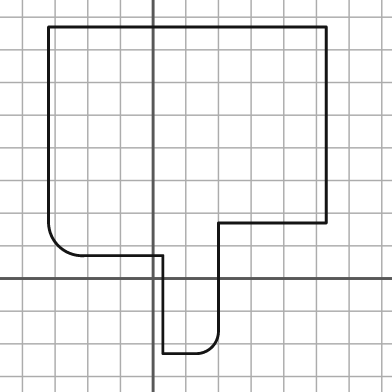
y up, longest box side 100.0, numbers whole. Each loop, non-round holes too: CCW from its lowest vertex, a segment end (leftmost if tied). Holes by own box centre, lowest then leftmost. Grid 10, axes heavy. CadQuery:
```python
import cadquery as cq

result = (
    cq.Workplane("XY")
    .moveTo(3.0, -23.0)
    .lineTo(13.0, -23.0)
    .threePointArc((18.0, -21.0), (20.0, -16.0))
    .lineTo(20.0, 17.0)
    .lineTo(53.0, 17.0)
    .lineTo(53.0, 77.0)
    .lineTo(-32.0, 77.0)
    .lineTo(-32.0, 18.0)
    .threePointArc((-29.0, 10.0), (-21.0, 7.0))
    .lineTo(3.0, 7.0)
    .close()
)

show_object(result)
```